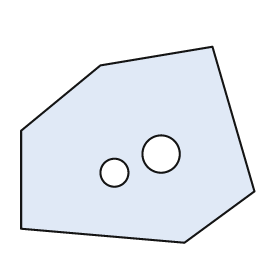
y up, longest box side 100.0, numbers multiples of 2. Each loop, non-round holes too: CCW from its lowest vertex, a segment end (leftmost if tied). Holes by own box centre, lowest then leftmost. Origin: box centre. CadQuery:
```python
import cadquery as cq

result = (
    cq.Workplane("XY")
    .moveTo(20.0, -42.0)
    .lineTo(50.0, -20.0)
    .lineTo(32.0, 42.0)
    .lineTo(-16.0, 34.0)
    .lineTo(-50.0, 6.0)
    .lineTo(-50.0, -36.0)
    .close()
    .moveTo(-10.0, -12.0)
    .circle(6.0)
    .moveTo(10.0, -4.0)
    .circle(8.0)
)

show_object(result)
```